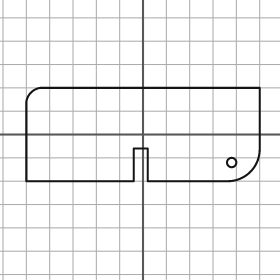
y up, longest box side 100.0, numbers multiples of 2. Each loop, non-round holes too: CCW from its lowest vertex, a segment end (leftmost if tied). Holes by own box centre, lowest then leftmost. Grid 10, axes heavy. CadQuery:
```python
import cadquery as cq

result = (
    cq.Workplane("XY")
    .moveTo(-50.0, -20.0)
    .lineTo(-4.0, -20.0)
    .lineTo(-4.0, -6.0)
    .lineTo(2.0, -6.0)
    .lineTo(2.0, -20.0)
    .lineTo(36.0, -20.0)
    .threePointArc((46.0, -16.0), (50.0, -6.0))
    .lineTo(50.0, 20.0)
    .lineTo(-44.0, 20.0)
    .threePointArc((-48.0, 18.0), (-50.0, 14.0))
    .close()
    .moveTo(38.0, -12.0)
    .circle(2.0)
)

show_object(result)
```